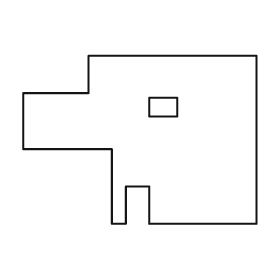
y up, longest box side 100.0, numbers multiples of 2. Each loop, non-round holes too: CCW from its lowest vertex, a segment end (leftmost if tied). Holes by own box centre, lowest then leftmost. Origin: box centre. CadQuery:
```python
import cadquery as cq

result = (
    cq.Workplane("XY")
    .moveTo(-12.0, -36.0)
    .lineTo(-6.0, -36.0)
    .lineTo(-6.0, -20.0)
    .lineTo(4.0, -20.0)
    .lineTo(4.0, -36.0)
    .lineTo(50.0, -36.0)
    .lineTo(50.0, 36.0)
    .lineTo(-22.0, 36.0)
    .lineTo(-22.0, 20.0)
    .lineTo(-50.0, 20.0)
    .lineTo(-50.0, -4.0)
    .lineTo(-12.0, -4.0)
    .close()
    .moveTo(4.0, 10.0)
    .lineTo(16.0, 10.0)
    .lineTo(16.0, 18.0)
    .lineTo(4.0, 18.0)
    .close()
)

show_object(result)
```